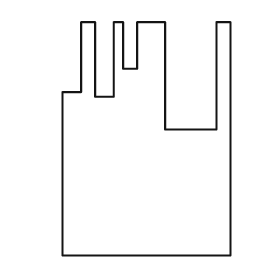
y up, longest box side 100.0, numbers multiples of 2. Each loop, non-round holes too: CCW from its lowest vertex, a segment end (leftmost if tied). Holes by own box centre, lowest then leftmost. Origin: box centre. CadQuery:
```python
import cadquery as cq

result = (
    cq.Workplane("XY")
    .moveTo(-36.0, -50.0)
    .lineTo(36.0, -50.0)
    .lineTo(36.0, 50.0)
    .lineTo(30.0, 50.0)
    .lineTo(30.0, 4.0)
    .lineTo(8.0, 4.0)
    .lineTo(8.0, 50.0)
    .lineTo(-4.0, 50.0)
    .lineTo(-4.0, 30.0)
    .lineTo(-10.0, 30.0)
    .lineTo(-10.0, 50.0)
    .lineTo(-14.0, 50.0)
    .lineTo(-14.0, 18.0)
    .lineTo(-22.0, 18.0)
    .lineTo(-22.0, 50.0)
    .lineTo(-28.0, 50.0)
    .lineTo(-28.0, 20.0)
    .lineTo(-36.0, 20.0)
    .close()
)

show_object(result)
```